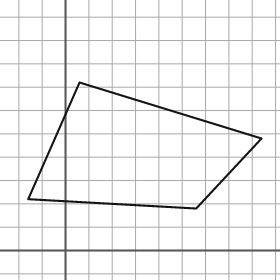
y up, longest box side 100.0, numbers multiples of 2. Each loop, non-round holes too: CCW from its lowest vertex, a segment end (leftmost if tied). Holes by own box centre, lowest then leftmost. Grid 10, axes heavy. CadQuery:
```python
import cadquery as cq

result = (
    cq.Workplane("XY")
    .moveTo(56.0, 18.0)
    .lineTo(84.0, 48.0)
    .lineTo(6.0, 72.0)
    .lineTo(-16.0, 22.0)
    .close()
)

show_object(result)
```